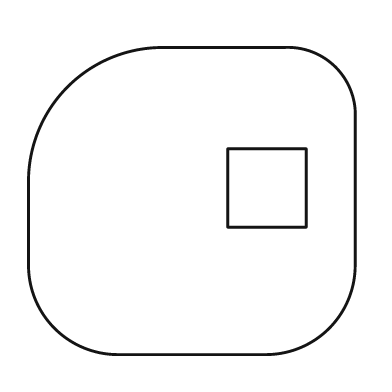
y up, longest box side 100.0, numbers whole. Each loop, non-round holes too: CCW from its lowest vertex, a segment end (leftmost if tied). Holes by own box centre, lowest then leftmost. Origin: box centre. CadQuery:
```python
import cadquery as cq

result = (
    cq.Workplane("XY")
    .moveTo(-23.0, -47.0)
    .lineTo(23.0, -47.0)
    .threePointArc((42.0, -39.0), (50.0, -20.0))
    .lineTo(50.0, 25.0)
    .threePointArc((44.0, 41.0), (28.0, 47.0))
    .lineTo(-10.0, 47.0)
    .threePointArc((-38.0, 35.0), (-50.0, 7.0))
    .lineTo(-50.0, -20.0)
    .threePointArc((-42.0, -39.0), (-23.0, -47.0))
    .close()
    .moveTo(11.0, -8.0)
    .lineTo(35.0, -8.0)
    .lineTo(35.0, 16.0)
    .lineTo(11.0, 16.0)
    .close()
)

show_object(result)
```